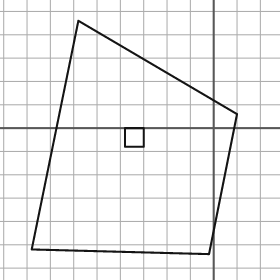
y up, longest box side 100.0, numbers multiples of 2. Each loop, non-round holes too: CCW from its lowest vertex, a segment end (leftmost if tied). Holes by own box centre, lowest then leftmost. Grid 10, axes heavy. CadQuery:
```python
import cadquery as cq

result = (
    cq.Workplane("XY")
    .moveTo(-2.0, -54.0)
    .lineTo(10.0, 6.0)
    .lineTo(-58.0, 46.0)
    .lineTo(-78.0, -52.0)
    .close()
    .moveTo(-38.0, -8.0)
    .lineTo(-30.0, -8.0)
    .lineTo(-30.0, 0.0)
    .lineTo(-38.0, 0.0)
    .close()
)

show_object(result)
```